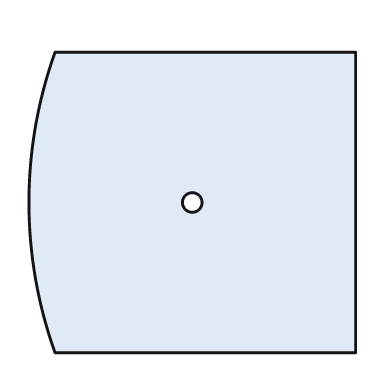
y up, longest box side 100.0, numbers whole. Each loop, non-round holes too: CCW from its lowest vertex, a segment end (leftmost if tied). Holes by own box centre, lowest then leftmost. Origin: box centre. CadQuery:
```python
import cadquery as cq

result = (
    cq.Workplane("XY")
    .moveTo(-42.0, -46.0)
    .lineTo(50.0, -46.0)
    .lineTo(50.0, 46.0)
    .lineTo(-42.0, 46.0)
    .threePointArc((-50.0, 0.0), (-42.0, -46.0))
    .close()
    .moveTo(0.0, 0.0)
    .circle(3.0)
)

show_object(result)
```